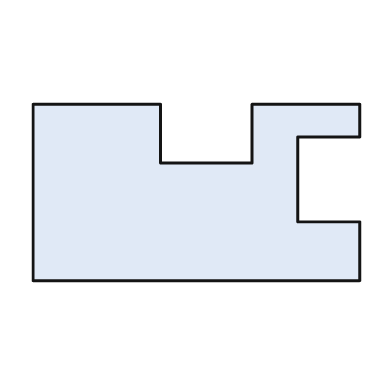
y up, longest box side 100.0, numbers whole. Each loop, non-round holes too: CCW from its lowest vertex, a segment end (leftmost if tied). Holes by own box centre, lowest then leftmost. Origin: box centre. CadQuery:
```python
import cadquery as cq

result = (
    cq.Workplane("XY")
    .moveTo(-50.0, -27.0)
    .lineTo(50.0, -27.0)
    .lineTo(50.0, -9.0)
    .lineTo(31.0, -9.0)
    .lineTo(31.0, 17.0)
    .lineTo(50.0, 17.0)
    .lineTo(50.0, 27.0)
    .lineTo(17.0, 27.0)
    .lineTo(17.0, 9.0)
    .lineTo(-11.0, 9.0)
    .lineTo(-11.0, 27.0)
    .lineTo(-50.0, 27.0)
    .close()
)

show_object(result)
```